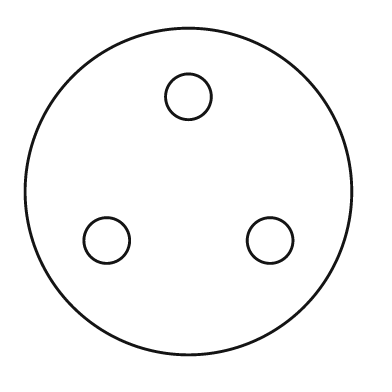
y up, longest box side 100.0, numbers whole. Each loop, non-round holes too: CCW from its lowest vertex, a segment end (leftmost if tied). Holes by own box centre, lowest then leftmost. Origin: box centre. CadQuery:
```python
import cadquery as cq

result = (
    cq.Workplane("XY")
    .moveTo(0.0, 0.0)
    .circle(50.0)
    .moveTo(-25.0, -15.0)
    .circle(7.0)
    .moveTo(25.0, -15.0)
    .circle(7.0)
    .moveTo(0.0, 29.0)
    .circle(7.0)
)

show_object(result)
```